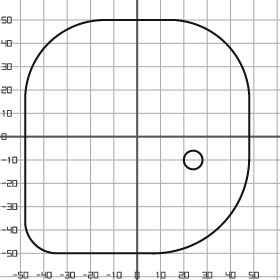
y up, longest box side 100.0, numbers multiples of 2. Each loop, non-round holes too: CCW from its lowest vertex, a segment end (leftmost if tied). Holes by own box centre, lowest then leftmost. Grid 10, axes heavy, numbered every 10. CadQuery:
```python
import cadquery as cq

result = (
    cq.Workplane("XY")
    .moveTo(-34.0, -50.0)
    .lineTo(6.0, -50.0)
    .threePointArc((36.0, -38.0), (48.0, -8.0))
    .lineTo(48.0, 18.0)
    .threePointArc((38.0, 40.0), (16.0, 50.0))
    .lineTo(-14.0, 50.0)
    .threePointArc((-38.0, 40.0), (-48.0, 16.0))
    .lineTo(-48.0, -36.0)
    .threePointArc((-44.0, -46.0), (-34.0, -50.0))
    .close()
    .moveTo(24.0, -10.0)
    .circle(4.0)
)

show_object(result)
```